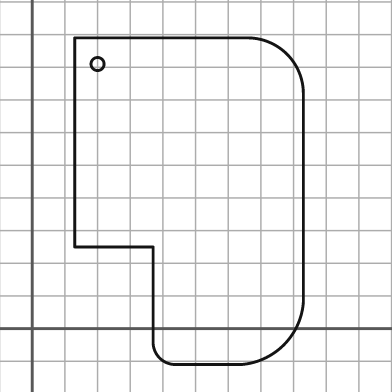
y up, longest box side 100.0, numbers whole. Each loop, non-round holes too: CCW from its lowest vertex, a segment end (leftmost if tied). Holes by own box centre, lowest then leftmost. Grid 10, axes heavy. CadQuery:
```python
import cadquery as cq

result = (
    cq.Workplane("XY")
    .moveTo(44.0, -11.0)
    .lineTo(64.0, -11.0)
    .threePointArc((77.0, -5.0), (83.0, 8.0))
    .lineTo(83.0, 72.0)
    .threePointArc((78.0, 84.0), (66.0, 89.0))
    .lineTo(13.0, 89.0)
    .lineTo(13.0, 25.0)
    .lineTo(37.0, 25.0)
    .lineTo(37.0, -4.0)
    .threePointArc((39.0, -9.0), (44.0, -11.0))
    .close()
    .moveTo(20.0, 81.0)
    .circle(2.0)
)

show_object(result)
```